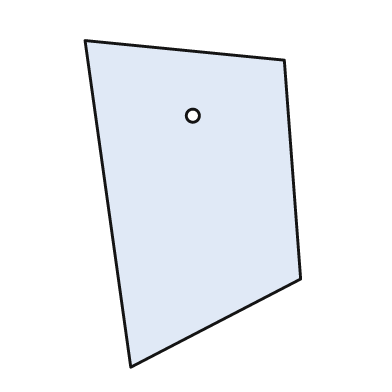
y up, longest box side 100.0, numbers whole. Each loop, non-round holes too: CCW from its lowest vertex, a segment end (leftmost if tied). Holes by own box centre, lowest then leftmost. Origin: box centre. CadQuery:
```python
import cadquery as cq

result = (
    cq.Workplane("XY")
    .moveTo(-19.0, -50.0)
    .lineTo(33.0, -23.0)
    .lineTo(28.0, 44.0)
    .lineTo(-33.0, 50.0)
    .close()
    .moveTo(0.0, 27.0)
    .circle(2.0)
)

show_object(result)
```